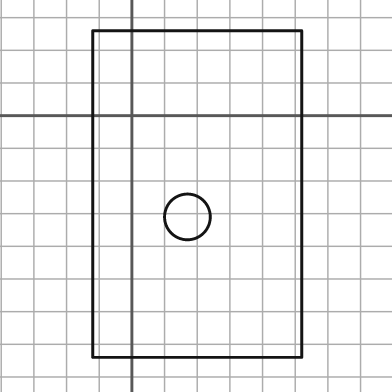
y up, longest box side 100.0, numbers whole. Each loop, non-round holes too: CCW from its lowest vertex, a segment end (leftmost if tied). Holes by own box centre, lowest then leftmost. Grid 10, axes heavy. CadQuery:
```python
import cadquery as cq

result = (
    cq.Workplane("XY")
    .moveTo(-12.0, -74.0)
    .lineTo(52.0, -74.0)
    .lineTo(52.0, 26.0)
    .lineTo(-12.0, 26.0)
    .close()
    .moveTo(17.0, -31.0)
    .circle(7.0)
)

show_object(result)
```